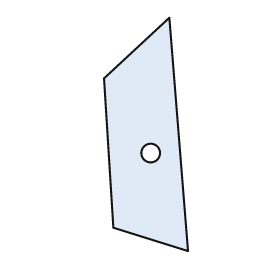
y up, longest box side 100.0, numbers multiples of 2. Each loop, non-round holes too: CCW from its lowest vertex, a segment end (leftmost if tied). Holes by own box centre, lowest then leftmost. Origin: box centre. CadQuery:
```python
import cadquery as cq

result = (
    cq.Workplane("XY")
    .moveTo(18.0, -50.0)
    .lineTo(10.0, 50.0)
    .lineTo(-18.0, 24.0)
    .lineTo(-14.0, -40.0)
    .close()
    .moveTo(2.0, -8.0)
    .circle(4.0)
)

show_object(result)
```